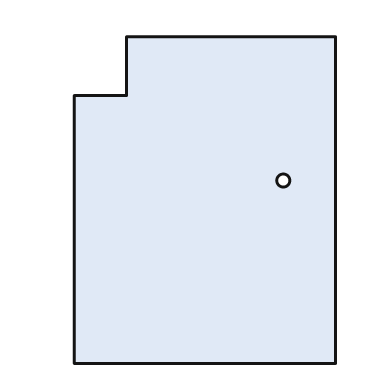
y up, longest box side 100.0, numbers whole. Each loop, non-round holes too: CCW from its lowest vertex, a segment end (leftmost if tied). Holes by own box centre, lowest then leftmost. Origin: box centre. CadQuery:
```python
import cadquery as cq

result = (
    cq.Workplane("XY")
    .moveTo(-40.0, -50.0)
    .lineTo(40.0, -50.0)
    .lineTo(40.0, 50.0)
    .lineTo(-24.0, 50.0)
    .lineTo(-24.0, 32.0)
    .lineTo(-40.0, 32.0)
    .close()
    .moveTo(24.0, 6.0)
    .circle(2.0)
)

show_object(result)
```